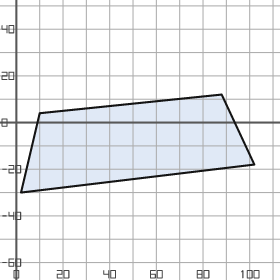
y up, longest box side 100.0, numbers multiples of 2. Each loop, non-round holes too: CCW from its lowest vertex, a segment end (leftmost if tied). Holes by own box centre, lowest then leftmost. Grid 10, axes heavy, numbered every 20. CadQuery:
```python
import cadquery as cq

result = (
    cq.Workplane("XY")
    .moveTo(2.0, -30.0)
    .lineTo(102.0, -18.0)
    .lineTo(88.0, 12.0)
    .lineTo(10.0, 4.0)
    .close()
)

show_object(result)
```